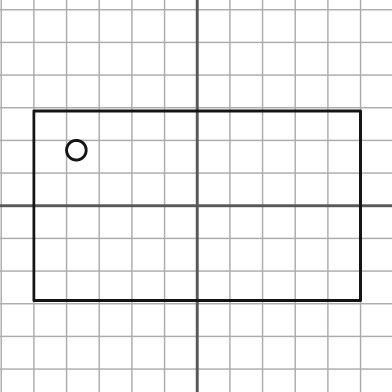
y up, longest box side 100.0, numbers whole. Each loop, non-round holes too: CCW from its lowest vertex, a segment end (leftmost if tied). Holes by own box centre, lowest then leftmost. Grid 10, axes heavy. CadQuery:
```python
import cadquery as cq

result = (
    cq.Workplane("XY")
    .moveTo(-50.0, -29.0)
    .lineTo(50.0, -29.0)
    .lineTo(50.0, 29.0)
    .lineTo(-50.0, 29.0)
    .close()
    .moveTo(-37.0, 17.0)
    .circle(3.0)
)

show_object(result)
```